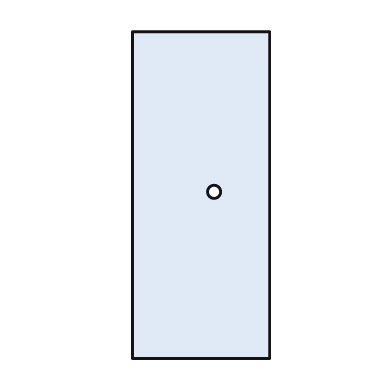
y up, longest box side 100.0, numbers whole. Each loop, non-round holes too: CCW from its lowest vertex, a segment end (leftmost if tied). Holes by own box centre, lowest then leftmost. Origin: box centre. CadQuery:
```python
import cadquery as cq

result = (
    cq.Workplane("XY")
    .moveTo(-21.0, -50.0)
    .lineTo(21.0, -50.0)
    .lineTo(21.0, 50.0)
    .lineTo(-21.0, 50.0)
    .close()
    .moveTo(4.0, 1.0)
    .circle(2.0)
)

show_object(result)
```